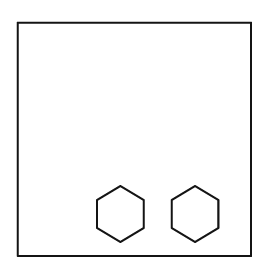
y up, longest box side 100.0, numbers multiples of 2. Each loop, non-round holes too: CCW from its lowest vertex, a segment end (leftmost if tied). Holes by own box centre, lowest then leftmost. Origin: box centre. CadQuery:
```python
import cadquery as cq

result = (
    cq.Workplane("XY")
    .moveTo(-50.0, -50.0)
    .lineTo(50.0, -50.0)
    .lineTo(50.0, 50.0)
    .lineTo(-50.0, 50.0)
    .close()
    .moveTo(-6.0, -44.0)
    .lineTo(4.0, -38.0)
    .lineTo(4.0, -26.0)
    .lineTo(-6.0, -20.0)
    .lineTo(-16.0, -26.0)
    .lineTo(-16.0, -38.0)
    .close()
    .moveTo(26.0, -44.0)
    .lineTo(36.0, -38.0)
    .lineTo(36.0, -26.0)
    .lineTo(26.0, -20.0)
    .lineTo(16.0, -26.0)
    .lineTo(16.0, -38.0)
    .close()
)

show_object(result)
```